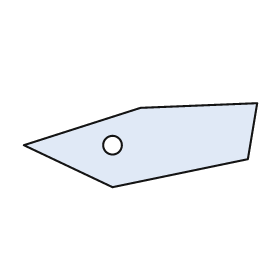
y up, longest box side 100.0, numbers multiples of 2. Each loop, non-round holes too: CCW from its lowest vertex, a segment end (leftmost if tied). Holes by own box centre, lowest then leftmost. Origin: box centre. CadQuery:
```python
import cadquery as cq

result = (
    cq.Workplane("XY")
    .moveTo(-12.0, -18.0)
    .lineTo(46.0, -6.0)
    .lineTo(50.0, 18.0)
    .lineTo(0.0, 16.0)
    .lineTo(-50.0, 0.0)
    .close()
    .moveTo(-12.0, 0.0)
    .circle(4.0)
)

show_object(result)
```